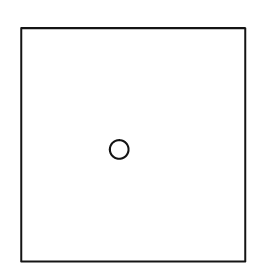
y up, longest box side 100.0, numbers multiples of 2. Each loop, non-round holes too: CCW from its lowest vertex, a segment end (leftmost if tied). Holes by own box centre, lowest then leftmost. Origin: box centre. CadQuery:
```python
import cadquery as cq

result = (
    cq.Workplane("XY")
    .moveTo(-48.0, -50.0)
    .lineTo(48.0, -50.0)
    .lineTo(48.0, 50.0)
    .lineTo(-48.0, 50.0)
    .close()
    .moveTo(-6.0, -2.0)
    .circle(4.0)
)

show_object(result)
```